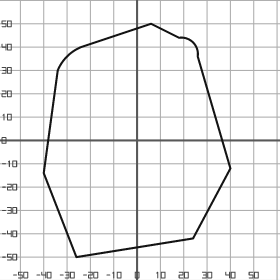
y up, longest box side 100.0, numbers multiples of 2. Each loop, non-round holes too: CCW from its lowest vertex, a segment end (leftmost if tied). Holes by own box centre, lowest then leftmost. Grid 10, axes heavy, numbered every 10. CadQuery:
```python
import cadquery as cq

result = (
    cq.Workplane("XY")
    .moveTo(-26.0, -50.0)
    .lineTo(24.0, -42.0)
    .lineTo(40.0, -12.0)
    .lineTo(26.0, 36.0)
    .threePointArc((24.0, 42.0), (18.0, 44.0))
    .lineTo(6.0, 50.0)
    .lineTo(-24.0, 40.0)
    .threePointArc((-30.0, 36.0), (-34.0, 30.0))
    .lineTo(-40.0, -14.0)
    .close()
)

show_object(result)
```